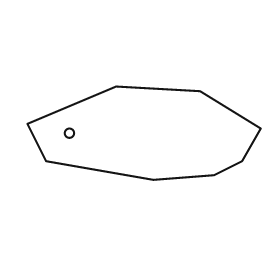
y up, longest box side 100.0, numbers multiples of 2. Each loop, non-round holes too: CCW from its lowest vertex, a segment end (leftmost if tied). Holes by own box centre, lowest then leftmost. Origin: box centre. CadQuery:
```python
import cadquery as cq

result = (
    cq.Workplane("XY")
    .moveTo(4.0, -20.0)
    .lineTo(30.0, -18.0)
    .lineTo(42.0, -12.0)
    .lineTo(50.0, 2.0)
    .lineTo(24.0, 18.0)
    .lineTo(-12.0, 20.0)
    .lineTo(-50.0, 4.0)
    .lineTo(-42.0, -12.0)
    .close()
    .moveTo(-32.0, 0.0)
    .circle(2.0)
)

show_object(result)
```